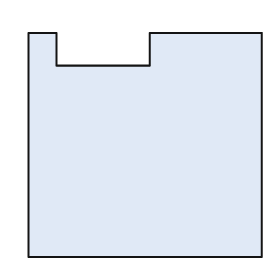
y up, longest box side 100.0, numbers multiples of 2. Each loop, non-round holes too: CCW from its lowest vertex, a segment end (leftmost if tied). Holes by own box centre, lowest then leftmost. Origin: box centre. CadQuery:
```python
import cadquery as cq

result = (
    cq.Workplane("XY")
    .moveTo(-50.0, -48.0)
    .lineTo(50.0, -48.0)
    .lineTo(50.0, 48.0)
    .lineTo(2.0, 48.0)
    .lineTo(2.0, 34.0)
    .lineTo(-38.0, 34.0)
    .lineTo(-38.0, 48.0)
    .lineTo(-50.0, 48.0)
    .close()
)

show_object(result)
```